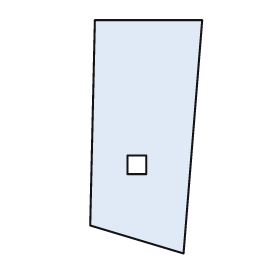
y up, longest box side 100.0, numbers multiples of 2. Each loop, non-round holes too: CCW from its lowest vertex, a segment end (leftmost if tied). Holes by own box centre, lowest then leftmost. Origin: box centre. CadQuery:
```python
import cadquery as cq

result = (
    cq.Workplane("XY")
    .moveTo(16.0, -50.0)
    .lineTo(24.0, 50.0)
    .lineTo(-22.0, 50.0)
    .lineTo(-24.0, -38.0)
    .close()
    .moveTo(-8.0, -16.0)
    .lineTo(0.0, -16.0)
    .lineTo(0.0, -8.0)
    .lineTo(-8.0, -8.0)
    .close()
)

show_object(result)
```